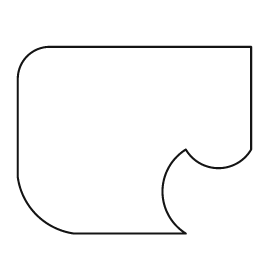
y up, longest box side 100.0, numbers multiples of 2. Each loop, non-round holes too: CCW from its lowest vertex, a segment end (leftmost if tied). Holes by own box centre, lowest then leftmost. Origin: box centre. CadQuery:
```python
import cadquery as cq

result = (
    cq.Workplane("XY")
    .moveTo(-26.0, -40.0)
    .lineTo(22.0, -40.0)
    .threePointArc((12.0, -22.0), (22.0, -4.0))
    .threePointArc((36.0, -12.0), (50.0, -4.0))
    .lineTo(50.0, 40.0)
    .lineTo(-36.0, 40.0)
    .threePointArc((-46.0, 36.0), (-50.0, 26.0))
    .lineTo(-50.0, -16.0)
    .threePointArc((-42.0, -32.0), (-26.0, -40.0))
    .close()
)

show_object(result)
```